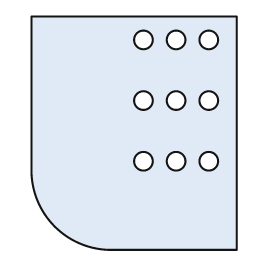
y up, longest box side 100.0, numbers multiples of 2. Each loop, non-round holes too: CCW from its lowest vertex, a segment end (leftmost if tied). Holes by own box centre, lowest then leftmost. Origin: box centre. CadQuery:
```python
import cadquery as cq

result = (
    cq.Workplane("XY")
    .moveTo(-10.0, -50.0)
    .lineTo(44.0, -50.0)
    .lineTo(44.0, 50.0)
    .lineTo(-44.0, 50.0)
    .lineTo(-44.0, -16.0)
    .threePointArc((-34.0, -40.0), (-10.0, -50.0))
    .close()
    .moveTo(4.0, -12.0)
    .circle(4.0)
    .moveTo(18.0, -12.0)
    .circle(4.0)
    .moveTo(32.0, -12.0)
    .circle(4.0)
    .moveTo(4.0, 14.0)
    .circle(4.0)
    .moveTo(18.0, 14.0)
    .circle(4.0)
    .moveTo(32.0, 14.0)
    .circle(4.0)
    .moveTo(4.0, 40.0)
    .circle(4.0)
    .moveTo(18.0, 40.0)
    .circle(4.0)
    .moveTo(32.0, 40.0)
    .circle(4.0)
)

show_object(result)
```